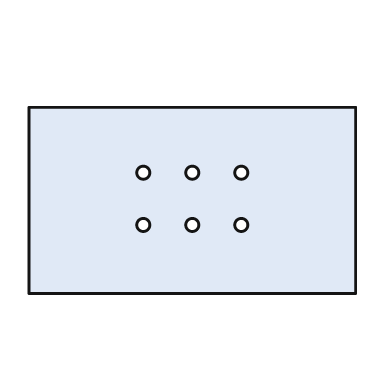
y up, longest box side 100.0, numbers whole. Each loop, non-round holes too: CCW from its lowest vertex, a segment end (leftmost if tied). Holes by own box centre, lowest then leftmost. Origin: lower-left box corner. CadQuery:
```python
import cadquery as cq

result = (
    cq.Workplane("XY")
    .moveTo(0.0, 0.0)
    .lineTo(100.0, 0.0)
    .lineTo(100.0, 57.0)
    .lineTo(0.0, 57.0)
    .close()
    .moveTo(35.0, 21.0)
    .circle(2.0)
    .moveTo(50.0, 21.0)
    .circle(2.0)
    .moveTo(65.0, 21.0)
    .circle(2.0)
    .moveTo(35.0, 37.0)
    .circle(2.0)
    .moveTo(50.0, 37.0)
    .circle(2.0)
    .moveTo(65.0, 37.0)
    .circle(2.0)
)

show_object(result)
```